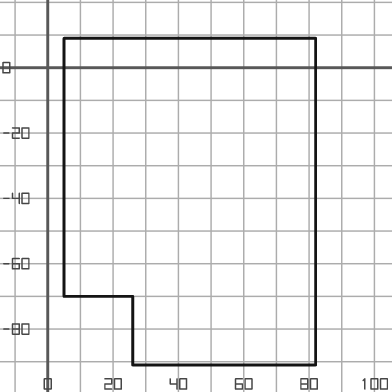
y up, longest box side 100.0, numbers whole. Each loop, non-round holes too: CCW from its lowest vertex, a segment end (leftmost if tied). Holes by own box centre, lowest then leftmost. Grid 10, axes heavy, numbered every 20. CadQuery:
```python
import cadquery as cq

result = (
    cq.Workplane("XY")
    .moveTo(26.0, -91.0)
    .lineTo(82.0, -91.0)
    .lineTo(82.0, 9.0)
    .lineTo(5.0, 9.0)
    .lineTo(5.0, -70.0)
    .lineTo(26.0, -70.0)
    .close()
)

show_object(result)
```